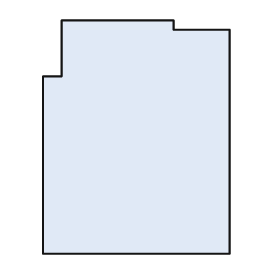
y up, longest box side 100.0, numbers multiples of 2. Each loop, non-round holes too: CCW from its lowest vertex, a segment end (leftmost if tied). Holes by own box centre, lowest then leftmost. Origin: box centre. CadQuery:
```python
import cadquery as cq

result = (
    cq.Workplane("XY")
    .moveTo(-40.0, -50.0)
    .lineTo(40.0, -50.0)
    .lineTo(40.0, 46.0)
    .lineTo(16.0, 46.0)
    .lineTo(16.0, 50.0)
    .lineTo(-32.0, 50.0)
    .lineTo(-32.0, 26.0)
    .lineTo(-40.0, 26.0)
    .close()
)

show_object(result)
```